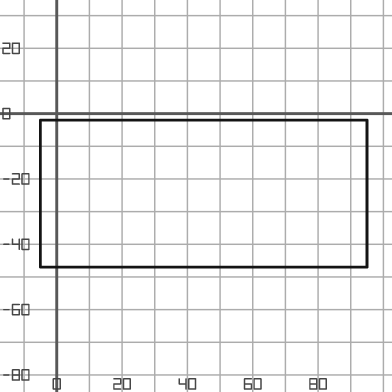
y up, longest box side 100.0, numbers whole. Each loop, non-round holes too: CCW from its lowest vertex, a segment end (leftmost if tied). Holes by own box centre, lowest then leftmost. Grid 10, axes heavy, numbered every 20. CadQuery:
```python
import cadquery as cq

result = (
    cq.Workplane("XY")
    .moveTo(-5.0, -47.0)
    .lineTo(95.0, -47.0)
    .lineTo(95.0, -2.0)
    .lineTo(-5.0, -2.0)
    .close()
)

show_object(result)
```